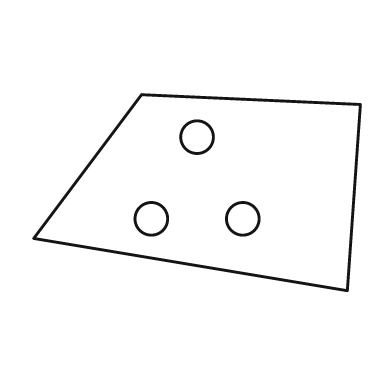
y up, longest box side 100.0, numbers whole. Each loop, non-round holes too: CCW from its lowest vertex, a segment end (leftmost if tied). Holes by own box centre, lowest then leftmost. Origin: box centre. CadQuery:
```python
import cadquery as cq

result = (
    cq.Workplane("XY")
    .moveTo(46.0, -30.0)
    .lineTo(50.0, 27.0)
    .lineTo(-17.0, 30.0)
    .lineTo(-50.0, -14.0)
    .close()
    .moveTo(-14.0, -8.0)
    .circle(5.0)
    .moveTo(14.0, -8.0)
    .circle(5.0)
    .moveTo(0.0, 17.0)
    .circle(5.0)
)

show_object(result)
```